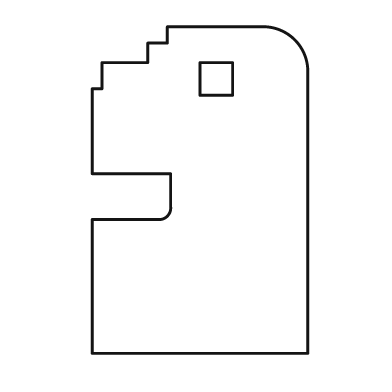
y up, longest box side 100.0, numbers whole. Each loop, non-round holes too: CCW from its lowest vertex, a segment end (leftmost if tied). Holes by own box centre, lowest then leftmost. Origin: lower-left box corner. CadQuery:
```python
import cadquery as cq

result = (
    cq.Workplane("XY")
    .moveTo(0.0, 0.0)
    .lineTo(66.0, 0.0)
    .lineTo(66.0, 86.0)
    .threePointArc((62.0, 96.0), (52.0, 100.0))
    .lineTo(23.0, 100.0)
    .lineTo(23.0, 95.0)
    .lineTo(17.0, 95.0)
    .lineTo(17.0, 89.0)
    .lineTo(3.0, 89.0)
    .lineTo(3.0, 81.0)
    .lineTo(0.0, 81.0)
    .lineTo(0.0, 55.0)
    .lineTo(24.0, 55.0)
    .lineTo(24.0, 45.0)
    .threePointArc((23.0, 42.0), (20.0, 41.0))
    .lineTo(0.0, 41.0)
    .close()
    .moveTo(33.0, 79.0)
    .lineTo(43.0, 79.0)
    .lineTo(43.0, 89.0)
    .lineTo(33.0, 89.0)
    .close()
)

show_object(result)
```